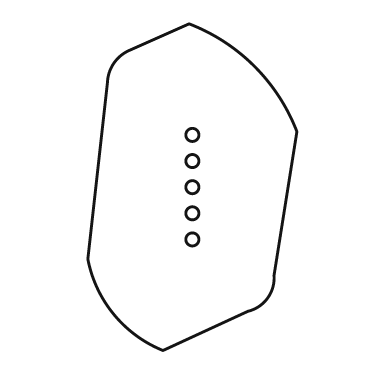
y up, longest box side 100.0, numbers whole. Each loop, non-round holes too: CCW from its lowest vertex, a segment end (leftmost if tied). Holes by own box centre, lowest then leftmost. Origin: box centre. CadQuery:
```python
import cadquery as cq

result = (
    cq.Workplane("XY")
    .moveTo(-9.0, -50.0)
    .lineTo(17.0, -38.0)
    .threePointArc((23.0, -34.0), (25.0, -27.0))
    .lineTo(32.0, 17.0)
    .threePointArc((19.0, 37.0), (-1.0, 50.0))
    .lineTo(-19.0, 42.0)
    .threePointArc((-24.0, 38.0), (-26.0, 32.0))
    .lineTo(-32.0, -22.0)
    .threePointArc((-24.0, -39.0), (-9.0, -50.0))
    .close()
    .moveTo(0.0, -16.0)
    .circle(2.0)
    .moveTo(0.0, -8.0)
    .circle(2.0)
    .moveTo(0.0, 0.0)
    .circle(2.0)
    .moveTo(0.0, 8.0)
    .circle(2.0)
    .moveTo(0.0, 16.0)
    .circle(2.0)
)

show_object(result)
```